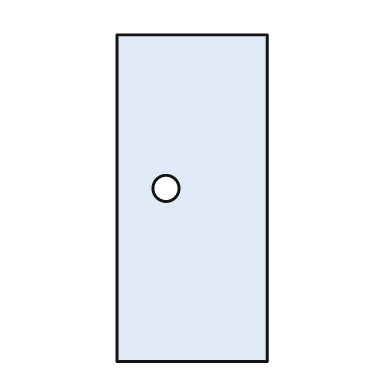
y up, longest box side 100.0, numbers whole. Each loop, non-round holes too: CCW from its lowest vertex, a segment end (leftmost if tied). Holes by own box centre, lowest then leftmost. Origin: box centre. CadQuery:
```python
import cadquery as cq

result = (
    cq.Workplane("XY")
    .moveTo(-23.0, -50.0)
    .lineTo(23.0, -50.0)
    .lineTo(23.0, 50.0)
    .lineTo(-23.0, 50.0)
    .close()
    .moveTo(-8.0, 3.0)
    .circle(4.0)
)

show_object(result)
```